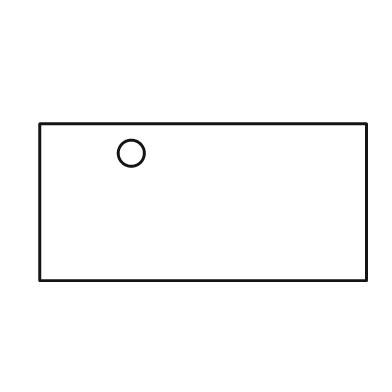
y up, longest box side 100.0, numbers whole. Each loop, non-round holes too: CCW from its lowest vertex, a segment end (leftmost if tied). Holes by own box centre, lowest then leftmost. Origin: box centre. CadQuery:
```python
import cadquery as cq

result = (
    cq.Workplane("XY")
    .moveTo(-50.0, -24.0)
    .lineTo(50.0, -24.0)
    .lineTo(50.0, 24.0)
    .lineTo(-50.0, 24.0)
    .close()
    .moveTo(-22.0, 15.0)
    .circle(4.0)
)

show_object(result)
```